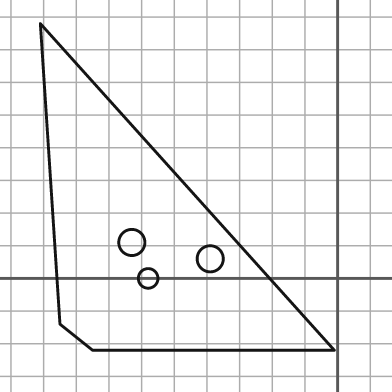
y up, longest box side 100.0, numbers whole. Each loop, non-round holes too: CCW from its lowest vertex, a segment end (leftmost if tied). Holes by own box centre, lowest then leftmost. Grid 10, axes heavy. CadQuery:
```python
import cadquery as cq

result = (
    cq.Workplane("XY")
    .moveTo(-75.0, -22.0)
    .lineTo(-1.0, -22.0)
    .lineTo(-91.0, 78.0)
    .lineTo(-85.0, -14.0)
    .close()
    .moveTo(-58.0, 0.0)
    .circle(3.0)
    .moveTo(-39.0, 6.0)
    .circle(4.0)
    .moveTo(-63.0, 11.0)
    .circle(4.0)
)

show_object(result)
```